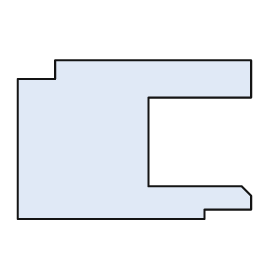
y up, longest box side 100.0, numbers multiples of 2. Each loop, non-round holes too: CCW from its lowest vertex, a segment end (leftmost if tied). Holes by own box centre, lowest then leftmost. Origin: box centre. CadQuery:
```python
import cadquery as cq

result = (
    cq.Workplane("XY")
    .moveTo(-50.0, -34.0)
    .lineTo(30.0, -34.0)
    .lineTo(30.0, -30.0)
    .lineTo(50.0, -30.0)
    .lineTo(50.0, -24.0)
    .lineTo(46.0, -20.0)
    .lineTo(6.0, -20.0)
    .lineTo(6.0, 18.0)
    .lineTo(50.0, 18.0)
    .lineTo(50.0, 34.0)
    .lineTo(-34.0, 34.0)
    .lineTo(-34.0, 26.0)
    .lineTo(-50.0, 26.0)
    .close()
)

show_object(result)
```